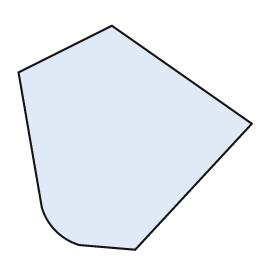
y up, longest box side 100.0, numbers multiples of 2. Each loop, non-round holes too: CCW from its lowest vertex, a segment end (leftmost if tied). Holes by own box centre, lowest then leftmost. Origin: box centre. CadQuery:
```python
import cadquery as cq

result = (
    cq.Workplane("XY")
    .moveTo(0.0, -48.0)
    .lineTo(50.0, 6.0)
    .lineTo(-10.0, 48.0)
    .lineTo(-50.0, 28.0)
    .lineTo(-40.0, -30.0)
    .threePointArc((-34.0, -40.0), (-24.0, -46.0))
    .close()
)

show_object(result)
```